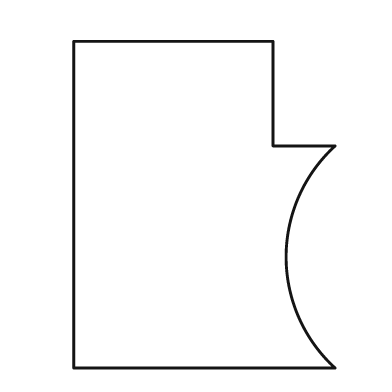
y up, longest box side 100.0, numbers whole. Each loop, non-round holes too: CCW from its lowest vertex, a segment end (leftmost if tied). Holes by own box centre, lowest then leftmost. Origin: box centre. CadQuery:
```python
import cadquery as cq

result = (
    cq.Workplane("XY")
    .moveTo(-40.0, -50.0)
    .lineTo(40.0, -50.0)
    .threePointArc((25.0, -16.0), (40.0, 18.0))
    .lineTo(21.0, 18.0)
    .lineTo(21.0, 50.0)
    .lineTo(-40.0, 50.0)
    .close()
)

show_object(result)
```